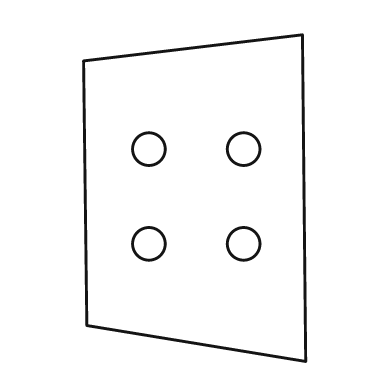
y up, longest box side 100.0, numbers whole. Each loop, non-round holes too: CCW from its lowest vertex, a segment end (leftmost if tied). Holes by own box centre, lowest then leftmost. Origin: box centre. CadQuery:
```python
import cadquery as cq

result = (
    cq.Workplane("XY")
    .moveTo(34.0, -50.0)
    .lineTo(33.0, 50.0)
    .lineTo(-34.0, 42.0)
    .lineTo(-33.0, -39.0)
    .close()
    .moveTo(-14.0, -14.0)
    .circle(5.0)
    .moveTo(15.0, -14.0)
    .circle(5.0)
    .moveTo(-14.0, 15.0)
    .circle(5.0)
    .moveTo(15.0, 15.0)
    .circle(5.0)
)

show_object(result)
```